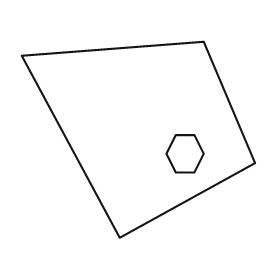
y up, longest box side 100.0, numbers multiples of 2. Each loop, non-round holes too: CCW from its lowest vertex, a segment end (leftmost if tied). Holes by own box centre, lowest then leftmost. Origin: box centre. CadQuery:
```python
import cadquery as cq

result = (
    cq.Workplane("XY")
    .moveTo(-8.0, -42.0)
    .lineTo(50.0, -10.0)
    .lineTo(28.0, 42.0)
    .lineTo(-50.0, 36.0)
    .close()
    .moveTo(16.0, -14.0)
    .lineTo(24.0, -14.0)
    .lineTo(28.0, -6.0)
    .lineTo(24.0, 2.0)
    .lineTo(16.0, 2.0)
    .lineTo(12.0, -6.0)
    .close()
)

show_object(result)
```